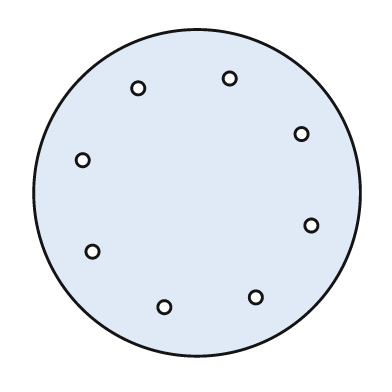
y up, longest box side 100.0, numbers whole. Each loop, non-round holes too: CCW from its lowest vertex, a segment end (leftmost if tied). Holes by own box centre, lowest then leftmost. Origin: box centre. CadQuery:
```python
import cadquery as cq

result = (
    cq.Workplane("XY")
    .moveTo(0.0, 0.0)
    .circle(50.0)
    .moveTo(-10.0, -35.0)
    .circle(2.0)
    .moveTo(18.0, -32.0)
    .circle(2.0)
    .moveTo(-32.0, -18.0)
    .circle(2.0)
    .moveTo(35.0, -10.0)
    .circle(2.0)
    .moveTo(-35.0, 10.0)
    .circle(2.0)
    .moveTo(32.0, 18.0)
    .circle(2.0)
    .moveTo(-18.0, 32.0)
    .circle(2.0)
    .moveTo(10.0, 35.0)
    .circle(2.0)
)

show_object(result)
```